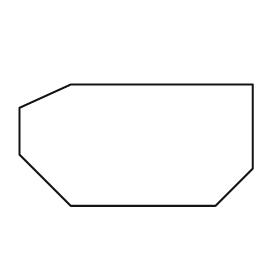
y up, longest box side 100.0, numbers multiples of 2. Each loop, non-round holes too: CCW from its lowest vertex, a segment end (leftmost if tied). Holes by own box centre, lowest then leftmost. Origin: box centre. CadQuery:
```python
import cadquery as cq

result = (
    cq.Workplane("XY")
    .moveTo(-28.0, -26.0)
    .lineTo(34.0, -26.0)
    .lineTo(50.0, -10.0)
    .lineTo(50.0, 26.0)
    .lineTo(-28.0, 26.0)
    .lineTo(-50.0, 16.0)
    .lineTo(-50.0, -4.0)
    .close()
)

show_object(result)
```